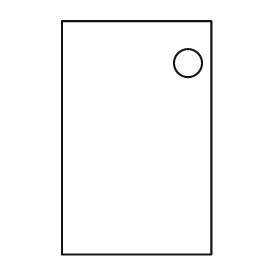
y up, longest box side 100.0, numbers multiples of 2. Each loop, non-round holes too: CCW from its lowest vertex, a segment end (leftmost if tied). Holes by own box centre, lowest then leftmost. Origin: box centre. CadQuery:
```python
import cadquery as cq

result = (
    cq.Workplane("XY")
    .moveTo(-32.0, -50.0)
    .lineTo(32.0, -50.0)
    .lineTo(32.0, 50.0)
    .lineTo(-32.0, 50.0)
    .close()
    .moveTo(22.0, 32.0)
    .circle(6.0)
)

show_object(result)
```